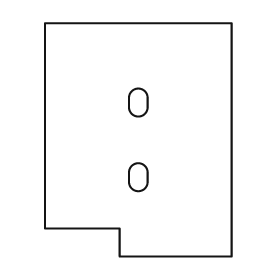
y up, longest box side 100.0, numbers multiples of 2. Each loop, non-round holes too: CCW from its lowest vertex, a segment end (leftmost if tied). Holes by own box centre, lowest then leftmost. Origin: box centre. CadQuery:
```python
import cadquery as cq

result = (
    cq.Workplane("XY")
    .moveTo(-8.0, -50.0)
    .lineTo(40.0, -50.0)
    .lineTo(40.0, 50.0)
    .lineTo(-40.0, 50.0)
    .lineTo(-40.0, -38.0)
    .lineTo(-8.0, -38.0)
    .close()
    .moveTo(-4.0, -18.0)
    .threePointArc((0.0, -22.0), (4.0, -18.0))
    .lineTo(4.0, -14.0)
    .threePointArc((0.0, -10.0), (-4.0, -14.0))
    .close()
    .moveTo(-4.0, 14.0)
    .threePointArc((0.0, 10.0), (4.0, 14.0))
    .lineTo(4.0, 18.0)
    .threePointArc((0.0, 22.0), (-4.0, 18.0))
    .close()
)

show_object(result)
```